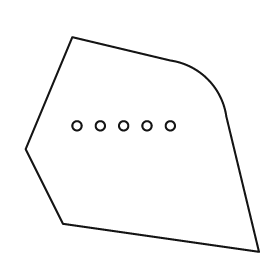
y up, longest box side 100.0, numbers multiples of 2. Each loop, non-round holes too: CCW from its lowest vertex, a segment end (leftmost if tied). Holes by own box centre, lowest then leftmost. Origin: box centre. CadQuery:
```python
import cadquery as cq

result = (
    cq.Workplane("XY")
    .moveTo(50.0, -46.0)
    .lineTo(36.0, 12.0)
    .threePointArc((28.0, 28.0), (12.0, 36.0))
    .lineTo(-30.0, 46.0)
    .lineTo(-50.0, -2.0)
    .lineTo(-34.0, -34.0)
    .close()
    .moveTo(-28.0, 8.0)
    .circle(2.0)
    .moveTo(-18.0, 8.0)
    .circle(2.0)
    .moveTo(-8.0, 8.0)
    .circle(2.0)
    .moveTo(2.0, 8.0)
    .circle(2.0)
    .moveTo(12.0, 8.0)
    .circle(2.0)
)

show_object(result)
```